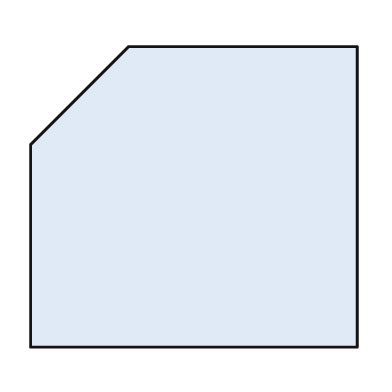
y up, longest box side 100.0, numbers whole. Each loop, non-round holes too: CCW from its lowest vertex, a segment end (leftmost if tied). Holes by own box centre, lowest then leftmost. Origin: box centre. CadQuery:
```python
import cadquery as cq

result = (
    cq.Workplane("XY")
    .moveTo(-50.0, -46.0)
    .lineTo(50.0, -46.0)
    .lineTo(50.0, 46.0)
    .lineTo(-20.0, 46.0)
    .lineTo(-50.0, 16.0)
    .close()
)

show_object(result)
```